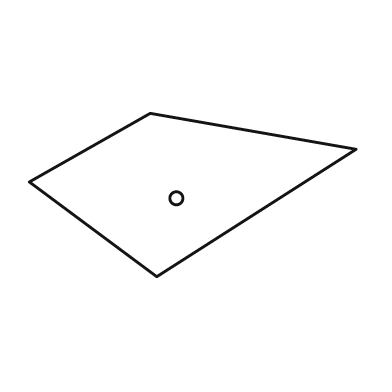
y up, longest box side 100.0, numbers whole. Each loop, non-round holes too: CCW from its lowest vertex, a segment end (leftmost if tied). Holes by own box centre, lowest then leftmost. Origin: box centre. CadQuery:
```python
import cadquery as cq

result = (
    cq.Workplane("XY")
    .moveTo(-11.0, -25.0)
    .lineTo(50.0, 14.0)
    .lineTo(-13.0, 25.0)
    .lineTo(-50.0, 4.0)
    .close()
    .moveTo(-5.0, -1.0)
    .circle(2.0)
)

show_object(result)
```